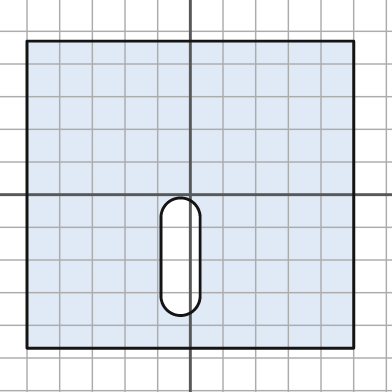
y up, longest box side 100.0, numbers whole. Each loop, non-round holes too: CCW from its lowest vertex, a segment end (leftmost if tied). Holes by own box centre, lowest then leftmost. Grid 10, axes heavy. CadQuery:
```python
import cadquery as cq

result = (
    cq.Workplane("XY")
    .moveTo(-50.0, -47.0)
    .lineTo(50.0, -47.0)
    .lineTo(50.0, 47.0)
    .lineTo(-50.0, 47.0)
    .close()
    .moveTo(-9.0, -31.0)
    .threePointArc((-3.0, -37.0), (3.0, -31.0))
    .lineTo(3.0, -7.0)
    .threePointArc((-3.0, -1.0), (-9.0, -7.0))
    .close()
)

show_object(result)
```